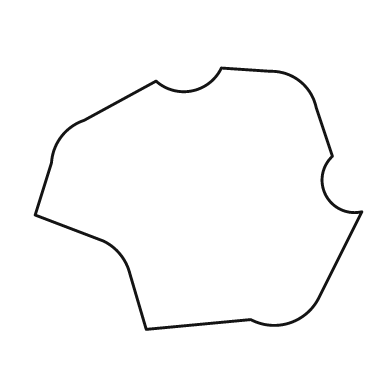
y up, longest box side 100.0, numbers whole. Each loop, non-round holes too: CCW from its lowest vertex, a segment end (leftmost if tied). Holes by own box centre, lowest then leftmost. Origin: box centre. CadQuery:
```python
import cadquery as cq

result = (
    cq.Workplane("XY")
    .moveTo(-16.0, -40.0)
    .lineTo(16.0, -37.0)
    .threePointArc((28.0, -38.0), (37.0, -30.0))
    .lineTo(50.0, -4.0)
    .threePointArc((39.0, 1.0), (41.0, 13.0))
    .lineTo(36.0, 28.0)
    .threePointArc((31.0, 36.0), (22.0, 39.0))
    .lineTo(7.0, 40.0)
    .threePointArc((-2.0, 33.0), (-13.0, 36.0))
    .lineTo(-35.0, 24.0)
    .threePointArc((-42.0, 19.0), (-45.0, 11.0))
    .lineTo(-50.0, -5.0)
    .lineTo(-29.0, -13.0)
    .threePointArc((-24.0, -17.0), (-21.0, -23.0))
    .close()
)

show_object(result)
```